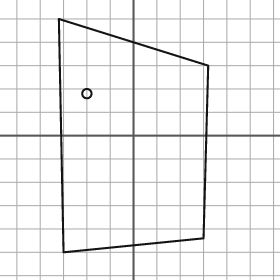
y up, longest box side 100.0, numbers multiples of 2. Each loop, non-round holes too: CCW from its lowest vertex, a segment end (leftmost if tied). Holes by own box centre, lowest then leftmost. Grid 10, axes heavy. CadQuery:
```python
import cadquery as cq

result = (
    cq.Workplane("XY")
    .moveTo(-30.0, -50.0)
    .lineTo(30.0, -44.0)
    .lineTo(32.0, 30.0)
    .lineTo(-32.0, 50.0)
    .close()
    .moveTo(-20.0, 18.0)
    .circle(2.0)
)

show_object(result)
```